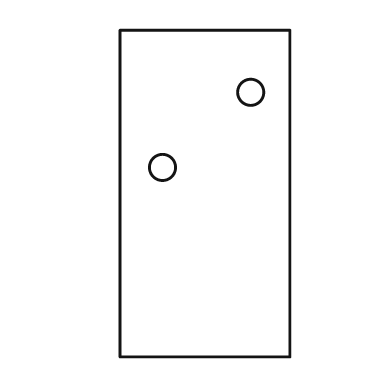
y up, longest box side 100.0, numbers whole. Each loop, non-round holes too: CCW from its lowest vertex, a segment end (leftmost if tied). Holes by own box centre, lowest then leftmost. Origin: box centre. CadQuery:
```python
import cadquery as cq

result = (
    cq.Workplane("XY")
    .moveTo(-26.0, -50.0)
    .lineTo(26.0, -50.0)
    .lineTo(26.0, 50.0)
    .lineTo(-26.0, 50.0)
    .close()
    .moveTo(-13.0, 8.0)
    .circle(4.0)
    .moveTo(14.0, 31.0)
    .circle(4.0)
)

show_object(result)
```